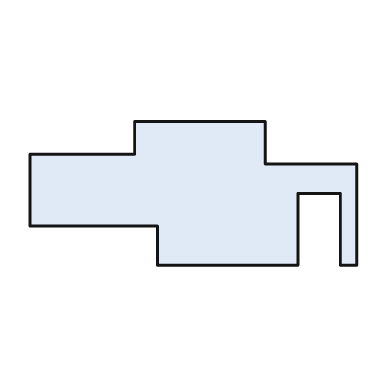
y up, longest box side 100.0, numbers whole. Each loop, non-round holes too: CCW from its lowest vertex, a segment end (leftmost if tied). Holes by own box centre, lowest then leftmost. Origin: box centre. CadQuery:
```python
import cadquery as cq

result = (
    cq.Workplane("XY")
    .moveTo(-11.0, -22.0)
    .lineTo(32.0, -22.0)
    .lineTo(32.0, 0.0)
    .lineTo(45.0, 0.0)
    .lineTo(45.0, -22.0)
    .lineTo(50.0, -22.0)
    .lineTo(50.0, 9.0)
    .lineTo(22.0, 9.0)
    .lineTo(22.0, 22.0)
    .lineTo(-18.0, 22.0)
    .lineTo(-18.0, 12.0)
    .lineTo(-50.0, 12.0)
    .lineTo(-50.0, -10.0)
    .lineTo(-11.0, -10.0)
    .close()
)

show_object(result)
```